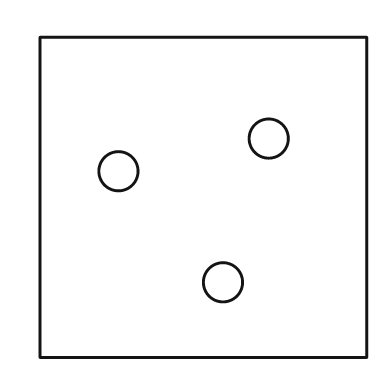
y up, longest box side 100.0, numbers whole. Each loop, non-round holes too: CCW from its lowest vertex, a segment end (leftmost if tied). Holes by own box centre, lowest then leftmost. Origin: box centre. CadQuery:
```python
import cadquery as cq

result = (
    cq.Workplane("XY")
    .moveTo(-50.0, -49.0)
    .lineTo(50.0, -49.0)
    .lineTo(50.0, 49.0)
    .lineTo(-50.0, 49.0)
    .close()
    .moveTo(6.0, -26.0)
    .circle(6.0)
    .moveTo(-26.0, 8.0)
    .circle(6.0)
    .moveTo(20.0, 18.0)
    .circle(6.0)
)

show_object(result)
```